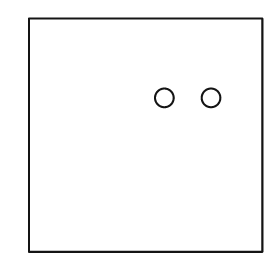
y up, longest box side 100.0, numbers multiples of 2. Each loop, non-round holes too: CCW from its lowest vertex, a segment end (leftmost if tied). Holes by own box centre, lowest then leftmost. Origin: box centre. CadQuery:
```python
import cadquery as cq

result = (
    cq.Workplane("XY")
    .moveTo(-50.0, -50.0)
    .lineTo(50.0, -50.0)
    .lineTo(50.0, 50.0)
    .lineTo(-50.0, 50.0)
    .close()
    .moveTo(8.0, 16.0)
    .circle(4.0)
    .moveTo(28.0, 16.0)
    .circle(4.0)
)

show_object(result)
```